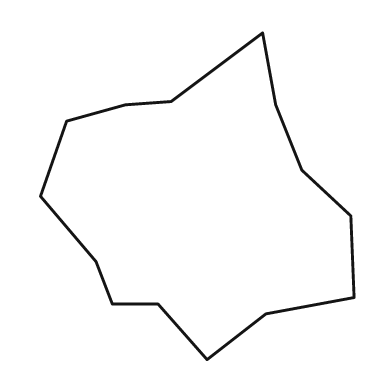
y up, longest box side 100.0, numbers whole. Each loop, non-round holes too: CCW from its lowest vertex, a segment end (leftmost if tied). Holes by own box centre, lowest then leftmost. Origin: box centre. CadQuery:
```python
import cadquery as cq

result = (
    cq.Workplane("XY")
    .moveTo(3.0, -50.0)
    .lineTo(21.0, -36.0)
    .lineTo(48.0, -31.0)
    .lineTo(47.0, -6.0)
    .lineTo(32.0, 8.0)
    .lineTo(24.0, 28.0)
    .lineTo(20.0, 50.0)
    .lineTo(-8.0, 29.0)
    .lineTo(-22.0, 28.0)
    .lineTo(-40.0, 23.0)
    .lineTo(-48.0, 0.0)
    .lineTo(-31.0, -20.0)
    .lineTo(-26.0, -33.0)
    .lineTo(-12.0, -33.0)
    .close()
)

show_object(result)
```